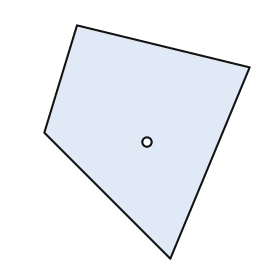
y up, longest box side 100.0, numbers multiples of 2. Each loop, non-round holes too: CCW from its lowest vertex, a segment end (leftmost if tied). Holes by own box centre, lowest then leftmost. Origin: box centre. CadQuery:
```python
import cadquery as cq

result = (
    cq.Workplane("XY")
    .moveTo(10.0, -50.0)
    .lineTo(44.0, 32.0)
    .lineTo(-30.0, 50.0)
    .lineTo(-44.0, 4.0)
    .close()
    .moveTo(0.0, 0.0)
    .circle(2.0)
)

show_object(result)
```